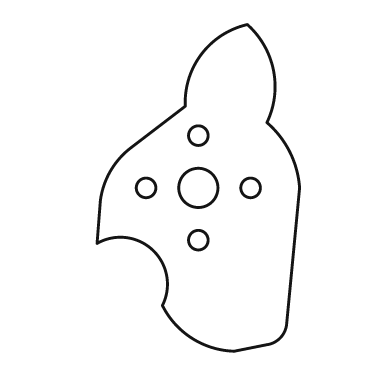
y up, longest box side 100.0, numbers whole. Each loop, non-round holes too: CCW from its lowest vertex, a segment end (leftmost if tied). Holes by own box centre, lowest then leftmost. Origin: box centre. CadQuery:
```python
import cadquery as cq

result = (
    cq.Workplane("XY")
    .moveTo(11.0, -50.0)
    .lineTo(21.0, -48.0)
    .threePointArc((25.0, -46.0), (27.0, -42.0))
    .lineTo(31.0, 0.0)
    .threePointArc((28.0, 11.0), (21.0, 20.0))
    .threePointArc((23.0, 36.0), (15.0, 50.0))
    .threePointArc((1.0, 41.0), (-4.0, 25.0))
    .lineTo(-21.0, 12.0)
    .threePointArc((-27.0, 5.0), (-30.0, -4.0))
    .lineTo(-31.0, -17.0)
    .threePointArc((-14.0, -19.0), (-11.0, -36.0))
    .threePointArc((-2.0, -46.0), (11.0, -50.0))
    .close()
    .moveTo(0.0, -16.0)
    .circle(3.0)
    .moveTo(-16.0, 0.0)
    .circle(3.0)
    .moveTo(0.0, 0.0)
    .circle(6.0)
    .moveTo(16.0, 0.0)
    .circle(3.0)
    .moveTo(0.0, 16.0)
    .circle(3.0)
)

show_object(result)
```